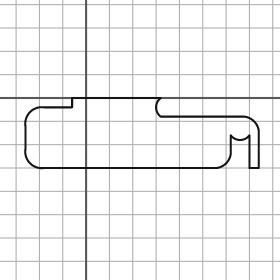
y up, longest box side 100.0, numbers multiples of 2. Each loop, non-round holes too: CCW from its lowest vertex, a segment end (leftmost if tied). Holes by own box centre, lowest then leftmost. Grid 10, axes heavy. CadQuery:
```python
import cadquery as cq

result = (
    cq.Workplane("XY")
    .moveTo(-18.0, -30.0)
    .lineTo(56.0, -30.0)
    .threePointArc((60.0, -28.0), (62.0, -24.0))
    .lineTo(62.0, -16.0)
    .threePointArc((66.0, -18.0), (70.0, -16.0))
    .lineTo(70.0, -30.0)
    .lineTo(74.0, -30.0)
    .lineTo(74.0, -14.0)
    .threePointArc((72.0, -10.0), (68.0, -8.0))
    .lineTo(32.0, -8.0)
    .threePointArc((30.0, -4.0), (32.0, 0.0))
    .lineTo(-6.0, 0.0)
    .lineTo(-6.0, -4.0)
    .lineTo(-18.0, -4.0)
    .threePointArc((-24.0, -6.0), (-26.0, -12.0))
    .lineTo(-26.0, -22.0)
    .threePointArc((-24.0, -28.0), (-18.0, -30.0))
    .close()
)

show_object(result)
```